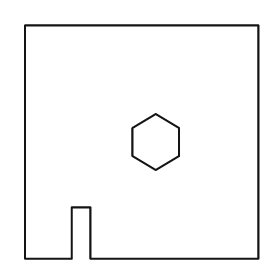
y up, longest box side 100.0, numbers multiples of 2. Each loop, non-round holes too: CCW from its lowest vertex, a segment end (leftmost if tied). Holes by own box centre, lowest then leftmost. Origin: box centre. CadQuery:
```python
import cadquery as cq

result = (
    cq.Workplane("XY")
    .moveTo(-50.0, -50.0)
    .lineTo(-30.0, -50.0)
    .lineTo(-30.0, -28.0)
    .lineTo(-22.0, -28.0)
    .lineTo(-22.0, -50.0)
    .lineTo(50.0, -50.0)
    .lineTo(50.0, 50.0)
    .lineTo(-50.0, 50.0)
    .close()
    .moveTo(6.0, -12.0)
    .lineTo(16.0, -6.0)
    .lineTo(16.0, 6.0)
    .lineTo(6.0, 12.0)
    .lineTo(-4.0, 6.0)
    .lineTo(-4.0, -6.0)
    .close()
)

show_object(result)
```